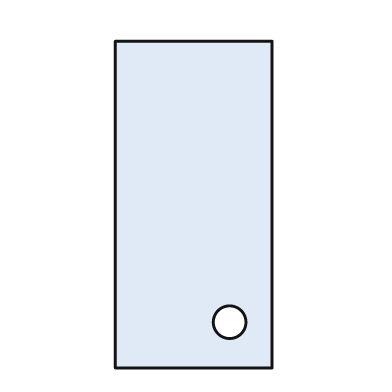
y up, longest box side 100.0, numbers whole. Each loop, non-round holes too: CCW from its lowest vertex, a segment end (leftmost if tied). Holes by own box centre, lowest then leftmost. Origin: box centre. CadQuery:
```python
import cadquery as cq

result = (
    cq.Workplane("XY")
    .moveTo(-24.0, -50.0)
    .lineTo(24.0, -50.0)
    .lineTo(24.0, 50.0)
    .lineTo(-24.0, 50.0)
    .close()
    .moveTo(11.0, -36.0)
    .circle(5.0)
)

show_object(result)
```